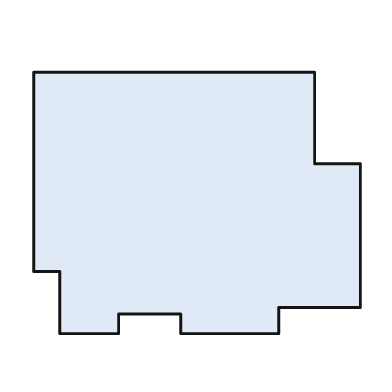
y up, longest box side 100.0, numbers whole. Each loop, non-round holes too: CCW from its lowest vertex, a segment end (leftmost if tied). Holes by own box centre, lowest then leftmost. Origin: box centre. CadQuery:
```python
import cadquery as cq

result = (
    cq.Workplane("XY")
    .moveTo(-42.0, -40.0)
    .lineTo(-24.0, -40.0)
    .lineTo(-24.0, -34.0)
    .lineTo(-5.0, -34.0)
    .lineTo(-5.0, -40.0)
    .lineTo(25.0, -40.0)
    .lineTo(25.0, -32.0)
    .lineTo(50.0, -32.0)
    .lineTo(50.0, 12.0)
    .lineTo(36.0, 12.0)
    .lineTo(36.0, 40.0)
    .lineTo(-50.0, 40.0)
    .lineTo(-50.0, -21.0)
    .lineTo(-42.0, -21.0)
    .close()
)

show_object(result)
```